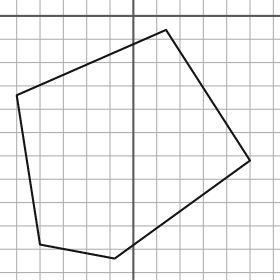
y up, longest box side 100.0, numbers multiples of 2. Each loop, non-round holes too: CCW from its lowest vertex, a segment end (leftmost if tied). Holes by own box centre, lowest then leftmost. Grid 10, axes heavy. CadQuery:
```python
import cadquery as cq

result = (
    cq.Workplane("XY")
    .moveTo(-8.0, -104.0)
    .lineTo(50.0, -62.0)
    .lineTo(14.0, -6.0)
    .lineTo(-50.0, -34.0)
    .lineTo(-40.0, -98.0)
    .close()
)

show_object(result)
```